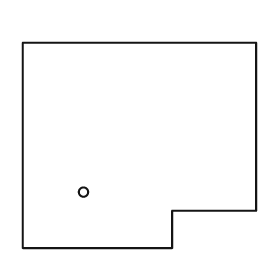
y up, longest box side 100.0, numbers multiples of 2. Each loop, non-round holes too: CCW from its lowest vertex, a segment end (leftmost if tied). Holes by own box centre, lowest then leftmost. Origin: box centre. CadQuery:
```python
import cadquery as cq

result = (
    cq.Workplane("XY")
    .moveTo(-50.0, -44.0)
    .lineTo(14.0, -44.0)
    .lineTo(14.0, -28.0)
    .lineTo(50.0, -28.0)
    .lineTo(50.0, 44.0)
    .lineTo(-50.0, 44.0)
    .close()
    .moveTo(-24.0, -20.0)
    .circle(2.0)
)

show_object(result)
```